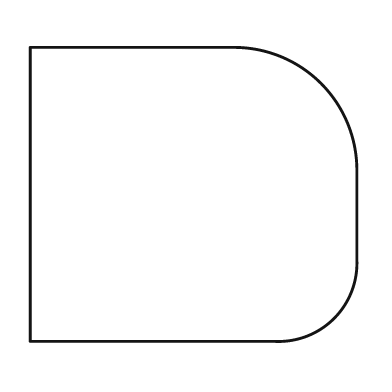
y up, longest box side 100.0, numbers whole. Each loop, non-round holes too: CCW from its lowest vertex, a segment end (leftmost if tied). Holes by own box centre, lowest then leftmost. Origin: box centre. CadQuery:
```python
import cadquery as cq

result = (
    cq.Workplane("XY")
    .moveTo(-50.0, -45.0)
    .lineTo(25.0, -45.0)
    .threePointArc((43.0, -38.0), (50.0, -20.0))
    .lineTo(50.0, 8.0)
    .threePointArc((39.0, 34.0), (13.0, 45.0))
    .lineTo(-50.0, 45.0)
    .close()
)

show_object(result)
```